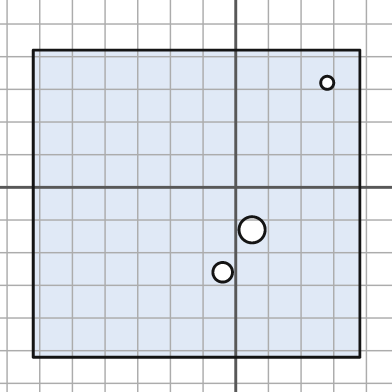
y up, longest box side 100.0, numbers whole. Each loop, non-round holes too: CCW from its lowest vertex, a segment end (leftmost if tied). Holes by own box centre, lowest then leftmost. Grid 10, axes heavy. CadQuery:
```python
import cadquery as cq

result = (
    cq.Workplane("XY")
    .moveTo(-62.0, -52.0)
    .lineTo(38.0, -52.0)
    .lineTo(38.0, 42.0)
    .lineTo(-62.0, 42.0)
    .close()
    .moveTo(-4.0, -26.0)
    .circle(3.0)
    .moveTo(5.0, -13.0)
    .circle(4.0)
    .moveTo(28.0, 32.0)
    .circle(2.0)
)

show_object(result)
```